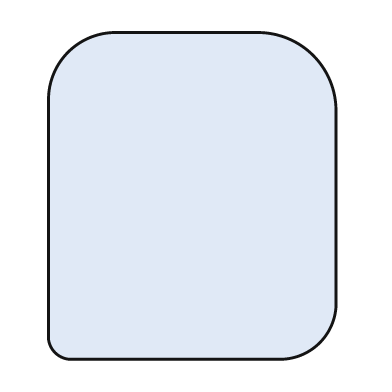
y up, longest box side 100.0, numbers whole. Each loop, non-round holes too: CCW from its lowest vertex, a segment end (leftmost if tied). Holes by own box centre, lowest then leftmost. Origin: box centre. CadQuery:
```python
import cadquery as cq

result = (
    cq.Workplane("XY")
    .moveTo(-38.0, -50.0)
    .lineTo(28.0, -50.0)
    .threePointArc((39.0, -45.0), (44.0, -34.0))
    .lineTo(44.0, 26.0)
    .threePointArc((37.0, 43.0), (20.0, 50.0))
    .lineTo(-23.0, 50.0)
    .threePointArc((-38.0, 44.0), (-44.0, 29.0))
    .lineTo(-44.0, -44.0)
    .threePointArc((-42.0, -48.0), (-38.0, -50.0))
    .close()
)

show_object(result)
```